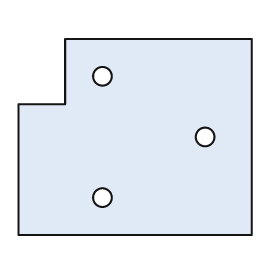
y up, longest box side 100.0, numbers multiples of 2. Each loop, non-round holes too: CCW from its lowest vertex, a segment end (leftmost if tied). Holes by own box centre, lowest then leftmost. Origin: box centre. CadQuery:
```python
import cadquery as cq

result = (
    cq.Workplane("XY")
    .moveTo(-50.0, -42.0)
    .lineTo(50.0, -42.0)
    .lineTo(50.0, 42.0)
    .lineTo(-30.0, 42.0)
    .lineTo(-30.0, 14.0)
    .lineTo(-50.0, 14.0)
    .close()
    .moveTo(-14.0, -26.0)
    .circle(4.0)
    .moveTo(30.0, 0.0)
    .circle(4.0)
    .moveTo(-14.0, 26.0)
    .circle(4.0)
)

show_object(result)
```